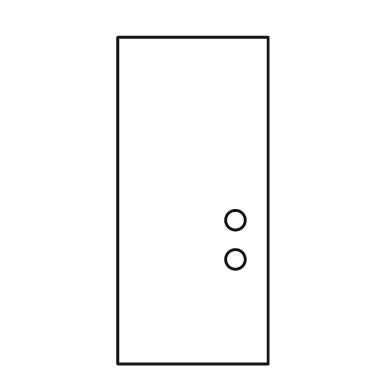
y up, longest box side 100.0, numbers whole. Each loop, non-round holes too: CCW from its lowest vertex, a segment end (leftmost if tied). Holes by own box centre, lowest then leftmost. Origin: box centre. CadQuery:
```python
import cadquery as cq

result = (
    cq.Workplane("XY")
    .moveTo(-23.0, -50.0)
    .lineTo(23.0, -50.0)
    .lineTo(23.0, 50.0)
    .lineTo(-23.0, 50.0)
    .close()
    .moveTo(13.0, -18.0)
    .circle(3.0)
    .moveTo(13.0, -6.0)
    .circle(3.0)
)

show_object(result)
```